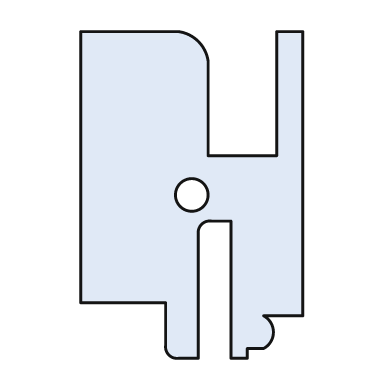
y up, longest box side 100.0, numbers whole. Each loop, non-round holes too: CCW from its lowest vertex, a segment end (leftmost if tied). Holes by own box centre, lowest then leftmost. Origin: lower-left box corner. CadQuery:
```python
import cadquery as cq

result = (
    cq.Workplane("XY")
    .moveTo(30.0, 0.0)
    .lineTo(36.0, 0.0)
    .lineTo(36.0, 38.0)
    .threePointArc((37.0, 41.0), (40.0, 42.0))
    .lineTo(46.0, 42.0)
    .lineTo(46.0, 0.0)
    .lineTo(51.0, 0.0)
    .lineTo(51.0, 3.0)
    .lineTo(56.0, 3.0)
    .threePointArc((59.0, 8.0), (56.0, 13.0))
    .lineTo(68.0, 13.0)
    .lineTo(68.0, 100.0)
    .lineTo(60.0, 100.0)
    .lineTo(60.0, 62.0)
    .lineTo(39.0, 62.0)
    .lineTo(39.0, 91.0)
    .threePointArc((36.0, 97.0), (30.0, 100.0))
    .lineTo(0.0, 100.0)
    .lineTo(0.0, 17.0)
    .lineTo(26.0, 17.0)
    .lineTo(26.0, 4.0)
    .threePointArc((27.0, 1.0), (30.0, 0.0))
    .close()
    .moveTo(34.0, 50.0)
    .circle(5.0)
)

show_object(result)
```